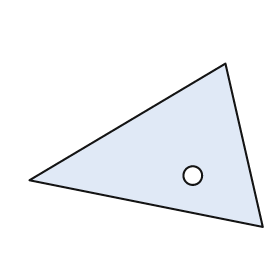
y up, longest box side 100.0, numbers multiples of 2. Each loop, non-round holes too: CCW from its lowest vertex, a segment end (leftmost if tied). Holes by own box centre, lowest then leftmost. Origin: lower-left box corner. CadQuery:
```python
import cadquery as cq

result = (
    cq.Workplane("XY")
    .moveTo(100.0, 0.0)
    .lineTo(84.0, 70.0)
    .lineTo(0.0, 20.0)
    .close()
    .moveTo(70.0, 22.0)
    .circle(4.0)
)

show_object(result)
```